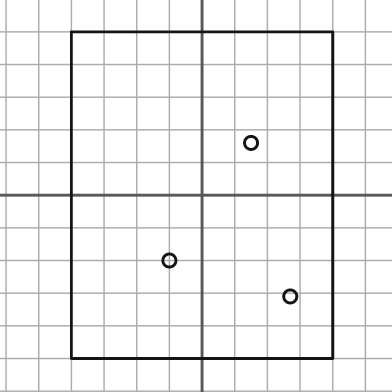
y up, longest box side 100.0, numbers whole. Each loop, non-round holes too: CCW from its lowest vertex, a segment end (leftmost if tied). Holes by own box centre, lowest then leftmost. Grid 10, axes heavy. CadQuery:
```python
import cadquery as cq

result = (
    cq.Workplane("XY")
    .moveTo(-40.0, -50.0)
    .lineTo(40.0, -50.0)
    .lineTo(40.0, 50.0)
    .lineTo(-40.0, 50.0)
    .close()
    .moveTo(27.0, -31.0)
    .circle(2.0)
    .moveTo(-10.0, -20.0)
    .circle(2.0)
    .moveTo(15.0, 16.0)
    .circle(2.0)
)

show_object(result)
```